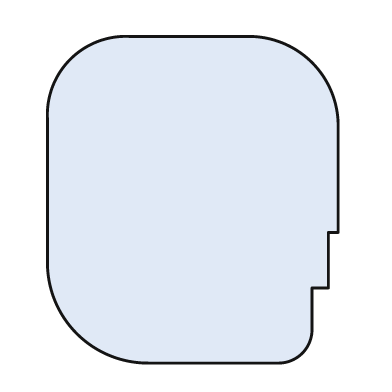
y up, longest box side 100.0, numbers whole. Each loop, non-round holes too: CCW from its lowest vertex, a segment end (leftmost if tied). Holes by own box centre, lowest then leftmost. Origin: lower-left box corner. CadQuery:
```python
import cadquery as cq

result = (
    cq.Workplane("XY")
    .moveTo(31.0, 0.0)
    .lineTo(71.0, 0.0)
    .threePointArc((78.0, 3.0), (81.0, 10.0))
    .lineTo(81.0, 23.0)
    .lineTo(86.0, 23.0)
    .lineTo(86.0, 40.0)
    .lineTo(89.0, 40.0)
    .lineTo(89.0, 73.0)
    .threePointArc((81.0, 92.0), (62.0, 100.0))
    .lineTo(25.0, 100.0)
    .threePointArc((7.0, 93.0), (0.0, 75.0))
    .lineTo(0.0, 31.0)
    .threePointArc((9.0, 9.0), (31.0, 0.0))
    .close()
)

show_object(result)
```